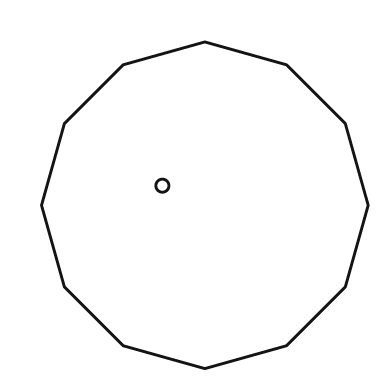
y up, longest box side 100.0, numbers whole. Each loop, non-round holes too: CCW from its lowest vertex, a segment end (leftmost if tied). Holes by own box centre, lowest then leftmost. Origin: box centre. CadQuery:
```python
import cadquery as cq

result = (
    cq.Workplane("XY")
    .moveTo(0.0, -50.0)
    .lineTo(25.0, -43.0)
    .lineTo(43.0, -25.0)
    .lineTo(50.0, 0.0)
    .lineTo(43.0, 25.0)
    .lineTo(25.0, 43.0)
    .lineTo(0.0, 50.0)
    .lineTo(-25.0, 43.0)
    .lineTo(-43.0, 25.0)
    .lineTo(-50.0, 0.0)
    .lineTo(-43.0, -25.0)
    .lineTo(-25.0, -43.0)
    .close()
    .moveTo(-13.0, 6.0)
    .circle(2.0)
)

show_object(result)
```